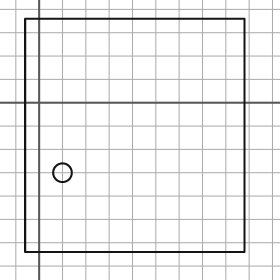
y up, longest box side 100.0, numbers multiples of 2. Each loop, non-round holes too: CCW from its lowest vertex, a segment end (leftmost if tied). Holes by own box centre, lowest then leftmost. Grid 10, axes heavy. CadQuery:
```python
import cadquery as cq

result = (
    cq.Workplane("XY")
    .moveTo(-6.0, -64.0)
    .lineTo(88.0, -64.0)
    .lineTo(88.0, 36.0)
    .lineTo(-6.0, 36.0)
    .close()
    .moveTo(10.0, -30.0)
    .circle(4.0)
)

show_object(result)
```